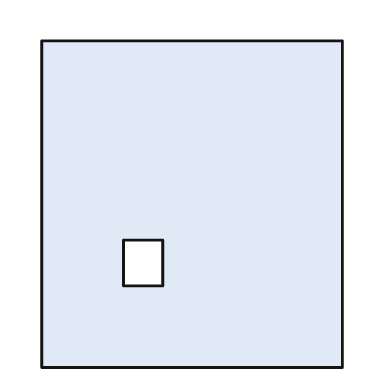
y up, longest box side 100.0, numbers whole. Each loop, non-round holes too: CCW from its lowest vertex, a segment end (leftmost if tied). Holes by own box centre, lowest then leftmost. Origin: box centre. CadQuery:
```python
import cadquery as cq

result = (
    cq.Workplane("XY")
    .moveTo(-46.0, -50.0)
    .lineTo(46.0, -50.0)
    .lineTo(46.0, 50.0)
    .lineTo(-46.0, 50.0)
    .close()
    .moveTo(-21.0, -25.0)
    .lineTo(-9.0, -25.0)
    .lineTo(-9.0, -11.0)
    .lineTo(-21.0, -11.0)
    .close()
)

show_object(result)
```